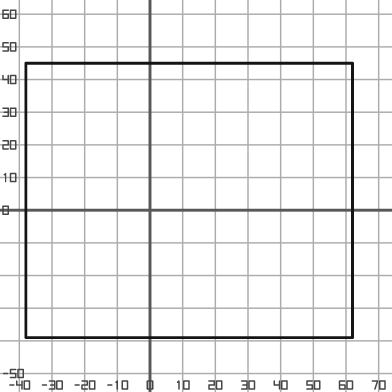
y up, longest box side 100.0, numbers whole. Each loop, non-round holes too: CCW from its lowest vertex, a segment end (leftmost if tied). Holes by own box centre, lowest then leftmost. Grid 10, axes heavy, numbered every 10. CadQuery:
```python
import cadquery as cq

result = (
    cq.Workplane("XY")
    .moveTo(-38.0, -39.0)
    .lineTo(62.0, -39.0)
    .lineTo(62.0, 45.0)
    .lineTo(-38.0, 45.0)
    .close()
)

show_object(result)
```